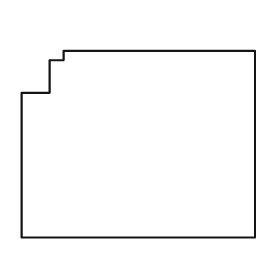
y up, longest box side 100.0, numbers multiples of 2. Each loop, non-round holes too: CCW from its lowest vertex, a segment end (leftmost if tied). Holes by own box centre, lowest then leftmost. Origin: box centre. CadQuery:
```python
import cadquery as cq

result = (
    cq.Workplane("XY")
    .moveTo(-50.0, -40.0)
    .lineTo(50.0, -40.0)
    .lineTo(50.0, 40.0)
    .lineTo(-32.0, 40.0)
    .lineTo(-32.0, 36.0)
    .lineTo(-38.0, 36.0)
    .lineTo(-38.0, 22.0)
    .lineTo(-50.0, 22.0)
    .close()
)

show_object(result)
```